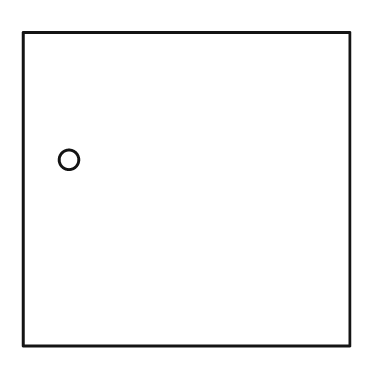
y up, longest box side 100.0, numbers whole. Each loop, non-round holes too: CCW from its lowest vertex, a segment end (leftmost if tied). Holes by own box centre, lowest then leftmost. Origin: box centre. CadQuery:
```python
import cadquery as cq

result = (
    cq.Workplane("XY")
    .moveTo(-50.0, -48.0)
    .lineTo(50.0, -48.0)
    .lineTo(50.0, 48.0)
    .lineTo(-50.0, 48.0)
    .close()
    .moveTo(-36.0, 9.0)
    .circle(3.0)
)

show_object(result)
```